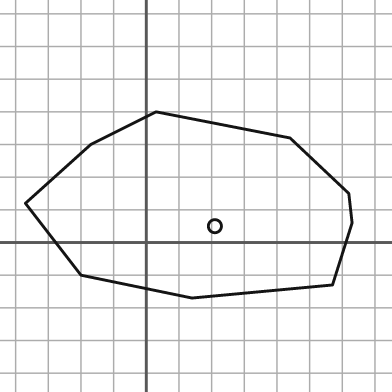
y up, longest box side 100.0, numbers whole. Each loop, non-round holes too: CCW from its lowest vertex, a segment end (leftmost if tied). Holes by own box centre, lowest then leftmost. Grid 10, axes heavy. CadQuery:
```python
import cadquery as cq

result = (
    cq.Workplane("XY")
    .moveTo(14.0, -17.0)
    .lineTo(57.0, -13.0)
    .lineTo(63.0, 6.0)
    .lineTo(62.0, 15.0)
    .lineTo(44.0, 32.0)
    .lineTo(3.0, 40.0)
    .lineTo(-17.0, 30.0)
    .lineTo(-37.0, 12.0)
    .lineTo(-20.0, -10.0)
    .close()
    .moveTo(21.0, 5.0)
    .circle(2.0)
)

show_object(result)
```